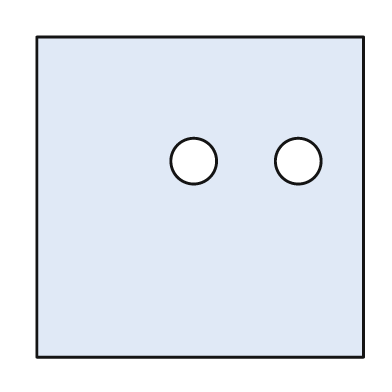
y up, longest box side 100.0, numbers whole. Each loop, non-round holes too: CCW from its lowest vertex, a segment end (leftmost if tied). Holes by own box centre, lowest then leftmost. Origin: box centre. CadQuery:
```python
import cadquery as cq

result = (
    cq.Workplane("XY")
    .moveTo(-50.0, -49.0)
    .lineTo(50.0, -49.0)
    .lineTo(50.0, 49.0)
    .lineTo(-50.0, 49.0)
    .close()
    .moveTo(-2.0, 11.0)
    .circle(7.0)
    .moveTo(30.0, 11.0)
    .circle(7.0)
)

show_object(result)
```